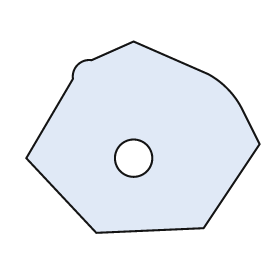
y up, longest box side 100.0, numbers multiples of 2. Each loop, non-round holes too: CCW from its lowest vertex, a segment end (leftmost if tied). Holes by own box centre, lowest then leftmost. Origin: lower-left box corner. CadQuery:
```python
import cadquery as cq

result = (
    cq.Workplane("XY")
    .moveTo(30.0, 0.0)
    .lineTo(76.0, 2.0)
    .lineTo(100.0, 38.0)
    .lineTo(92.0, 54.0)
    .threePointArc((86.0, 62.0), (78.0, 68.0))
    .lineTo(46.0, 82.0)
    .lineTo(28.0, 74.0)
    .threePointArc((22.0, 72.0), (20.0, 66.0))
    .lineTo(0.0, 32.0)
    .close()
    .moveTo(46.0, 32.0)
    .circle(8.0)
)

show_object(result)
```